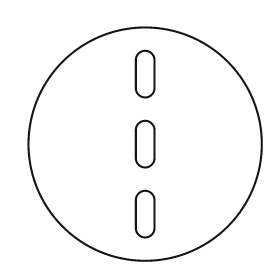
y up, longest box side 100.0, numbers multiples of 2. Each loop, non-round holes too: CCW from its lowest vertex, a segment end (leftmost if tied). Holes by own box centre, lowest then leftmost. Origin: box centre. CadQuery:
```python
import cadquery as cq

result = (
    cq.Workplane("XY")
    .moveTo(0.0, 0.0)
    .circle(50.0)
    .moveTo(-4.0, -36.0)
    .threePointArc((0.0, -40.0), (4.0, -36.0))
    .lineTo(4.0, -24.0)
    .threePointArc((0.0, -20.0), (-4.0, -24.0))
    .close()
    .moveTo(-4.0, -6.0)
    .threePointArc((0.0, -10.0), (4.0, -6.0))
    .lineTo(4.0, 6.0)
    .threePointArc((0.0, 10.0), (-4.0, 6.0))
    .close()
    .moveTo(-4.0, 24.0)
    .threePointArc((0.0, 20.0), (4.0, 24.0))
    .lineTo(4.0, 36.0)
    .threePointArc((0.0, 40.0), (-4.0, 36.0))
    .close()
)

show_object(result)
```